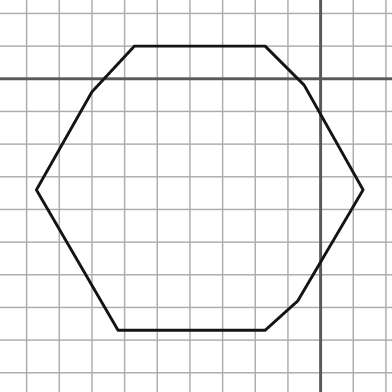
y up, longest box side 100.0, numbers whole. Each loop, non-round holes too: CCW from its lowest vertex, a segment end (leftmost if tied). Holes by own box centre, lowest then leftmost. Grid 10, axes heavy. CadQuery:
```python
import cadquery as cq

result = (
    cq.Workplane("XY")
    .moveTo(-62.0, -77.0)
    .lineTo(-17.0, -77.0)
    .lineTo(-7.0, -68.0)
    .lineTo(13.0, -34.0)
    .lineTo(-5.0, -2.0)
    .lineTo(-17.0, 10.0)
    .lineTo(-57.0, 10.0)
    .lineTo(-70.0, -4.0)
    .lineTo(-87.0, -34.0)
    .close()
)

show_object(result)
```